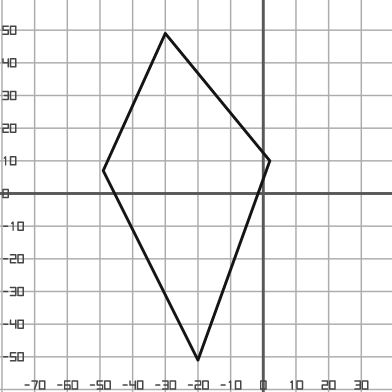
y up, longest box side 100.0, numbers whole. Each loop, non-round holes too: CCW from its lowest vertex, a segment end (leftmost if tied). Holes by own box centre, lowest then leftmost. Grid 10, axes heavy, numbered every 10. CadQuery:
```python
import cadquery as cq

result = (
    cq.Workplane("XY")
    .moveTo(-20.0, -51.0)
    .lineTo(2.0, 10.0)
    .lineTo(-30.0, 49.0)
    .lineTo(-49.0, 7.0)
    .close()
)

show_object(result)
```